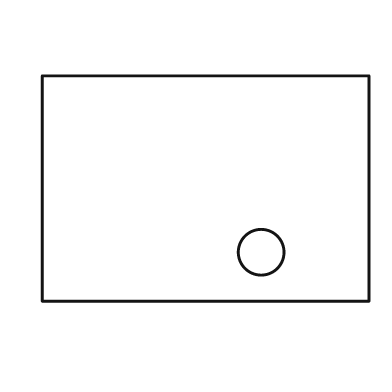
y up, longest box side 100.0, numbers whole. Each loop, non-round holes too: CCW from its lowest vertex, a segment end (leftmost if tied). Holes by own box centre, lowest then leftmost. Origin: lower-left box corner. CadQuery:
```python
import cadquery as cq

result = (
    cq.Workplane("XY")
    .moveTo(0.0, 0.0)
    .lineTo(100.0, 0.0)
    .lineTo(100.0, 69.0)
    .lineTo(0.0, 69.0)
    .close()
    .moveTo(67.0, 15.0)
    .circle(7.0)
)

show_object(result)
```